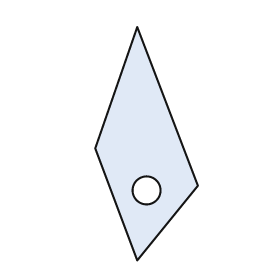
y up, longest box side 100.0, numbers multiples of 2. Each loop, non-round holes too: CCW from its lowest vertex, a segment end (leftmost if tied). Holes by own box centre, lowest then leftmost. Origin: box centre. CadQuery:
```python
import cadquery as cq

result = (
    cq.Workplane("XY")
    .moveTo(-4.0, -50.0)
    .lineTo(22.0, -18.0)
    .lineTo(-4.0, 50.0)
    .lineTo(-22.0, -2.0)
    .close()
    .moveTo(0.0, -20.0)
    .circle(6.0)
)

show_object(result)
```